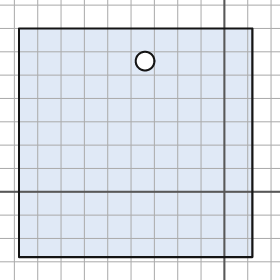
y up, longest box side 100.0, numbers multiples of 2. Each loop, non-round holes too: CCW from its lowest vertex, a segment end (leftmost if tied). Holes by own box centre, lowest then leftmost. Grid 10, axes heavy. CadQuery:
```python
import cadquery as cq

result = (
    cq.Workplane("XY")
    .moveTo(-88.0, -28.0)
    .lineTo(12.0, -28.0)
    .lineTo(12.0, 70.0)
    .lineTo(-88.0, 70.0)
    .close()
    .moveTo(-34.0, 56.0)
    .circle(4.0)
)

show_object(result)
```